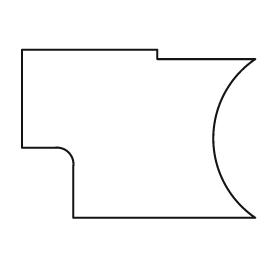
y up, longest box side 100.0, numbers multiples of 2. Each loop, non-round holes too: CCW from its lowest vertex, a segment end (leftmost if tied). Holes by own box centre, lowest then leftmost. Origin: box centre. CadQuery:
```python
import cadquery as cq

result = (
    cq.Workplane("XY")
    .moveTo(-28.0, -36.0)
    .lineTo(50.0, -36.0)
    .threePointArc((32.0, -2.0), (50.0, 32.0))
    .lineTo(8.0, 32.0)
    .lineTo(8.0, 36.0)
    .lineTo(-50.0, 36.0)
    .lineTo(-50.0, -6.0)
    .lineTo(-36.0, -6.0)
    .threePointArc((-30.0, -8.0), (-28.0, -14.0))
    .close()
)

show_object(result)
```